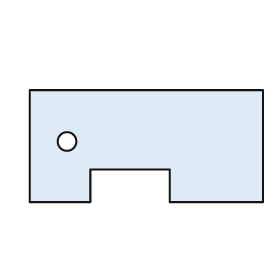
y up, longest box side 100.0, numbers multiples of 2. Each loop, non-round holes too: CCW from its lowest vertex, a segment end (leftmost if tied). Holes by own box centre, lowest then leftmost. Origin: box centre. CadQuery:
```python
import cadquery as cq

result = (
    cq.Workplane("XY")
    .moveTo(-50.0, -24.0)
    .lineTo(-24.0, -24.0)
    .lineTo(-24.0, -10.0)
    .lineTo(10.0, -10.0)
    .lineTo(10.0, -24.0)
    .lineTo(50.0, -24.0)
    .lineTo(50.0, 24.0)
    .lineTo(-50.0, 24.0)
    .close()
    .moveTo(-34.0, 2.0)
    .circle(4.0)
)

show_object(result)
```